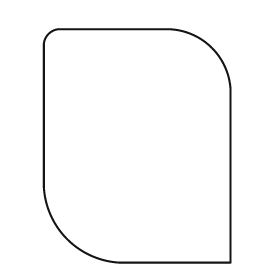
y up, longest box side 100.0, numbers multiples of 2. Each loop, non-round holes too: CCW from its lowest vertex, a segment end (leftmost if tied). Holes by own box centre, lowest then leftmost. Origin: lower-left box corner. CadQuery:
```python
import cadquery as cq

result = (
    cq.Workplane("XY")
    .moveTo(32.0, 0.0)
    .lineTo(80.0, 0.0)
    .lineTo(80.0, 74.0)
    .threePointArc((72.0, 92.0), (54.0, 100.0))
    .lineTo(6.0, 100.0)
    .threePointArc((2.0, 98.0), (0.0, 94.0))
    .lineTo(0.0, 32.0)
    .threePointArc((10.0, 10.0), (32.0, 0.0))
    .close()
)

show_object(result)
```